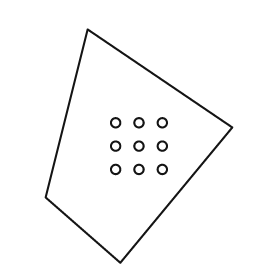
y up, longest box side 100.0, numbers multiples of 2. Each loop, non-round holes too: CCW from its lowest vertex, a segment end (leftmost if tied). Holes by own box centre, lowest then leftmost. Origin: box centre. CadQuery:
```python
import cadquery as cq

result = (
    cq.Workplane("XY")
    .moveTo(-8.0, -50.0)
    .lineTo(40.0, 8.0)
    .lineTo(-22.0, 50.0)
    .lineTo(-40.0, -22.0)
    .close()
    .moveTo(-10.0, -10.0)
    .circle(2.0)
    .moveTo(0.0, -10.0)
    .circle(2.0)
    .moveTo(10.0, -10.0)
    .circle(2.0)
    .moveTo(-10.0, 0.0)
    .circle(2.0)
    .moveTo(0.0, 0.0)
    .circle(2.0)
    .moveTo(10.0, 0.0)
    .circle(2.0)
    .moveTo(-10.0, 10.0)
    .circle(2.0)
    .moveTo(0.0, 10.0)
    .circle(2.0)
    .moveTo(10.0, 10.0)
    .circle(2.0)
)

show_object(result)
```